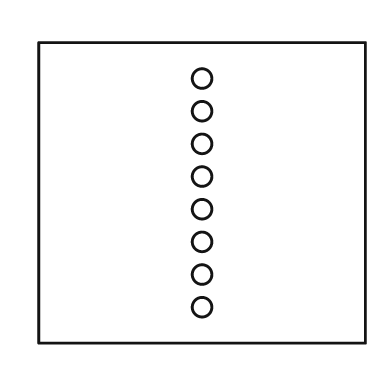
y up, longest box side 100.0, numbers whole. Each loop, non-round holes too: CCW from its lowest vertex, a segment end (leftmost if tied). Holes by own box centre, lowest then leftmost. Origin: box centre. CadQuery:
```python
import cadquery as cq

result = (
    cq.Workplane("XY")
    .moveTo(-50.0, -46.0)
    .lineTo(50.0, -46.0)
    .lineTo(50.0, 46.0)
    .lineTo(-50.0, 46.0)
    .close()
    .moveTo(0.0, -35.0)
    .circle(3.0)
    .moveTo(0.0, -25.0)
    .circle(3.0)
    .moveTo(0.0, -15.0)
    .circle(3.0)
    .moveTo(0.0, -5.0)
    .circle(3.0)
    .moveTo(0.0, 5.0)
    .circle(3.0)
    .moveTo(0.0, 15.0)
    .circle(3.0)
    .moveTo(0.0, 25.0)
    .circle(3.0)
    .moveTo(0.0, 35.0)
    .circle(3.0)
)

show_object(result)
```